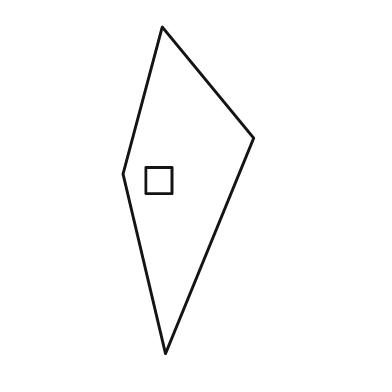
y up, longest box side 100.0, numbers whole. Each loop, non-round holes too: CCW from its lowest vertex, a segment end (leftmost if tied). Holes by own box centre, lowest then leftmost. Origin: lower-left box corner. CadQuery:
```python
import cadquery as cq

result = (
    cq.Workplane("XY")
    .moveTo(13.0, 0.0)
    .lineTo(40.0, 66.0)
    .lineTo(12.0, 100.0)
    .lineTo(0.0, 55.0)
    .close()
    .moveTo(7.0, 49.0)
    .lineTo(15.0, 49.0)
    .lineTo(15.0, 57.0)
    .lineTo(7.0, 57.0)
    .close()
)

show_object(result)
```